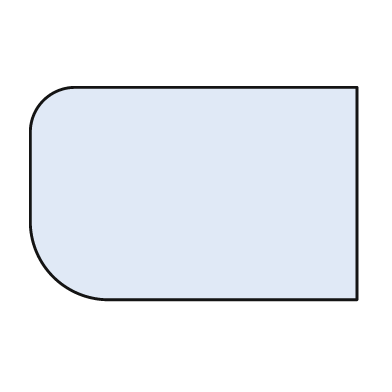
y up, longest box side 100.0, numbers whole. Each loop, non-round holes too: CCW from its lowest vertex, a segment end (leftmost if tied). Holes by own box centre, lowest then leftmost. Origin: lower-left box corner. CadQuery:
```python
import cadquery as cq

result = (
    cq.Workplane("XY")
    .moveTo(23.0, 0.0)
    .lineTo(100.0, 0.0)
    .lineTo(100.0, 65.0)
    .lineTo(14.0, 65.0)
    .threePointArc((4.0, 61.0), (0.0, 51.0))
    .lineTo(0.0, 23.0)
    .threePointArc((7.0, 7.0), (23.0, 0.0))
    .close()
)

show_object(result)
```